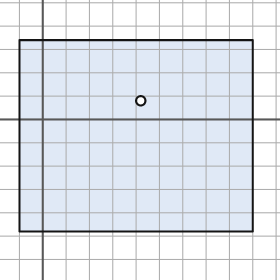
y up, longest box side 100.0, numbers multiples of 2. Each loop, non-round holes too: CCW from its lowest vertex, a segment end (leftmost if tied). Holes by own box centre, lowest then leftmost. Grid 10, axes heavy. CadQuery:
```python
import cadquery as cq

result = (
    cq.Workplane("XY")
    .moveTo(-10.0, -48.0)
    .lineTo(90.0, -48.0)
    .lineTo(90.0, 34.0)
    .lineTo(-10.0, 34.0)
    .close()
    .moveTo(42.0, 8.0)
    .circle(2.0)
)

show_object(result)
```